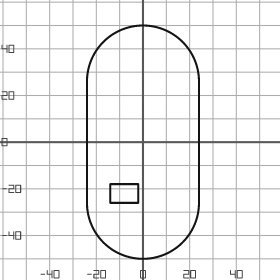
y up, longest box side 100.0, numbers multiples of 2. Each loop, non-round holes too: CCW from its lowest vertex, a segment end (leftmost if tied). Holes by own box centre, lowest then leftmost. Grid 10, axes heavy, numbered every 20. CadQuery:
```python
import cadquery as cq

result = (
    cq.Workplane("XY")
    .moveTo(-24.0, -26.0)
    .threePointArc((0.0, -50.0), (24.0, -26.0))
    .lineTo(24.0, 26.0)
    .threePointArc((0.0, 50.0), (-24.0, 26.0))
    .close()
    .moveTo(-14.0, -26.0)
    .lineTo(-2.0, -26.0)
    .lineTo(-2.0, -18.0)
    .lineTo(-14.0, -18.0)
    .close()
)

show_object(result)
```